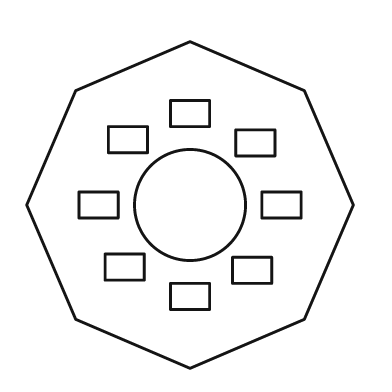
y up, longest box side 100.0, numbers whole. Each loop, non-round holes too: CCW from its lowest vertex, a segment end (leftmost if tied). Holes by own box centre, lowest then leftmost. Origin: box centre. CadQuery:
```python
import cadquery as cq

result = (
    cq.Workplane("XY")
    .moveTo(0.0, -50.0)
    .lineTo(35.0, -35.0)
    .lineTo(50.0, 0.0)
    .lineTo(35.0, 35.0)
    .lineTo(0.0, 50.0)
    .lineTo(-35.0, 35.0)
    .lineTo(-50.0, 0.0)
    .lineTo(-35.0, -35.0)
    .close()
    .moveTo(-6.0, -32.0)
    .lineTo(6.0, -32.0)
    .lineTo(6.0, -24.0)
    .lineTo(-6.0, -24.0)
    .close()
    .moveTo(13.0, -24.0)
    .lineTo(25.0, -24.0)
    .lineTo(25.0, -16.0)
    .lineTo(13.0, -16.0)
    .close()
    .moveTo(-26.0, -23.0)
    .lineTo(-14.0, -23.0)
    .lineTo(-14.0, -15.0)
    .lineTo(-26.0, -15.0)
    .close()
    .moveTo(-34.0, -4.0)
    .lineTo(-22.0, -4.0)
    .lineTo(-22.0, 4.0)
    .lineTo(-34.0, 4.0)
    .close()
    .moveTo(0.0, 0.0)
    .circle(17.0)
    .moveTo(22.0, -4.0)
    .lineTo(34.0, -4.0)
    .lineTo(34.0, 4.0)
    .lineTo(22.0, 4.0)
    .close()
    .moveTo(14.0, 15.0)
    .lineTo(26.0, 15.0)
    .lineTo(26.0, 23.0)
    .lineTo(14.0, 23.0)
    .close()
    .moveTo(-25.0, 16.0)
    .lineTo(-13.0, 16.0)
    .lineTo(-13.0, 24.0)
    .lineTo(-25.0, 24.0)
    .close()
    .moveTo(-6.0, 24.0)
    .lineTo(6.0, 24.0)
    .lineTo(6.0, 32.0)
    .lineTo(-6.0, 32.0)
    .close()
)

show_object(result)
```